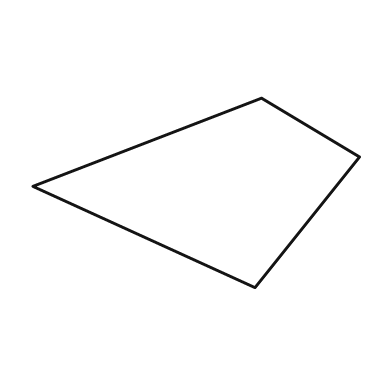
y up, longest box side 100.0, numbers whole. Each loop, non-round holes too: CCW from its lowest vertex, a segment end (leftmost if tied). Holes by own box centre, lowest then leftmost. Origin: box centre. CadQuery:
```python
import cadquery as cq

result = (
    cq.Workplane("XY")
    .moveTo(18.0, -29.0)
    .lineTo(50.0, 11.0)
    .lineTo(20.0, 29.0)
    .lineTo(-50.0, 2.0)
    .close()
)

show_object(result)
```